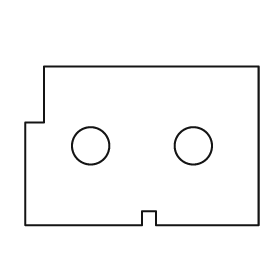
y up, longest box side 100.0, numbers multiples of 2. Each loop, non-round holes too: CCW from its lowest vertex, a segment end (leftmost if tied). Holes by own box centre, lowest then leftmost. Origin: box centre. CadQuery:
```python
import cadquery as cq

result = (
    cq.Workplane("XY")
    .moveTo(-50.0, -34.0)
    .lineTo(0.0, -34.0)
    .lineTo(0.0, -28.0)
    .lineTo(6.0, -28.0)
    .lineTo(6.0, -34.0)
    .lineTo(50.0, -34.0)
    .lineTo(50.0, 34.0)
    .lineTo(-42.0, 34.0)
    .lineTo(-42.0, 10.0)
    .lineTo(-50.0, 10.0)
    .close()
    .moveTo(-22.0, 0.0)
    .circle(8.0)
    .moveTo(22.0, 0.0)
    .circle(8.0)
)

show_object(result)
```